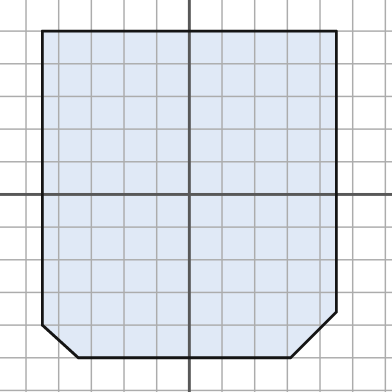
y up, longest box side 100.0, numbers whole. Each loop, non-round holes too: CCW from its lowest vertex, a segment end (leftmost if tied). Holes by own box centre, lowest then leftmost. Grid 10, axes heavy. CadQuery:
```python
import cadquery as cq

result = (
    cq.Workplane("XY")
    .moveTo(-34.0, -50.0)
    .lineTo(31.0, -50.0)
    .lineTo(45.0, -36.0)
    .lineTo(45.0, 50.0)
    .lineTo(-45.0, 50.0)
    .lineTo(-45.0, -40.0)
    .close()
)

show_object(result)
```